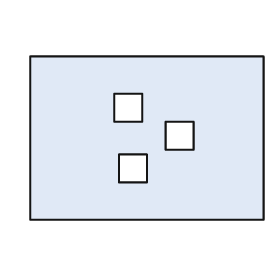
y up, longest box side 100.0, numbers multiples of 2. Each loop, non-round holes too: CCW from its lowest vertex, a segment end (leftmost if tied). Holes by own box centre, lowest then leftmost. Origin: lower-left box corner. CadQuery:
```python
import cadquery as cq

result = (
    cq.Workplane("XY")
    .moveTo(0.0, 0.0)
    .lineTo(100.0, 0.0)
    .lineTo(100.0, 70.0)
    .lineTo(0.0, 70.0)
    .close()
    .moveTo(38.0, 16.0)
    .lineTo(50.0, 16.0)
    .lineTo(50.0, 28.0)
    .lineTo(38.0, 28.0)
    .close()
    .moveTo(58.0, 30.0)
    .lineTo(70.0, 30.0)
    .lineTo(70.0, 42.0)
    .lineTo(58.0, 42.0)
    .close()
    .moveTo(36.0, 42.0)
    .lineTo(48.0, 42.0)
    .lineTo(48.0, 54.0)
    .lineTo(36.0, 54.0)
    .close()
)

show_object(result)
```